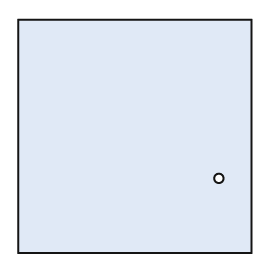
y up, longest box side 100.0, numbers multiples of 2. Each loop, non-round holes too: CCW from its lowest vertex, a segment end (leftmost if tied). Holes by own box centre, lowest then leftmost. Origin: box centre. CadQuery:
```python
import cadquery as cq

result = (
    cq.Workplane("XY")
    .moveTo(-50.0, -50.0)
    .lineTo(50.0, -50.0)
    .lineTo(50.0, 50.0)
    .lineTo(-50.0, 50.0)
    .close()
    .moveTo(36.0, -18.0)
    .circle(2.0)
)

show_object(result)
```